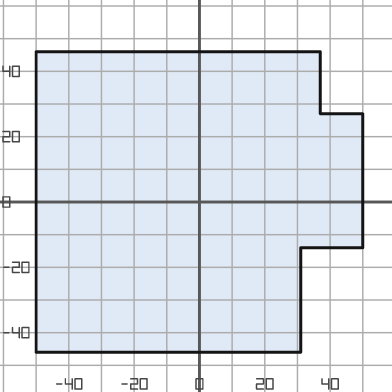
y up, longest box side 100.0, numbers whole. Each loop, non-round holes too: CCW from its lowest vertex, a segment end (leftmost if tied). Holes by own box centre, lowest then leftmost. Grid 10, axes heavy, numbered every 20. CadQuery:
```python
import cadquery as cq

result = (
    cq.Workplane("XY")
    .moveTo(-50.0, -46.0)
    .lineTo(31.0, -46.0)
    .lineTo(31.0, -14.0)
    .lineTo(50.0, -14.0)
    .lineTo(50.0, 27.0)
    .lineTo(37.0, 27.0)
    .lineTo(37.0, 46.0)
    .lineTo(-50.0, 46.0)
    .close()
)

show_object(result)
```